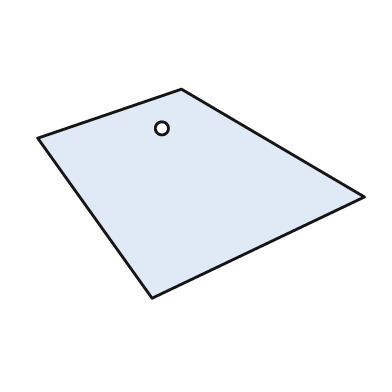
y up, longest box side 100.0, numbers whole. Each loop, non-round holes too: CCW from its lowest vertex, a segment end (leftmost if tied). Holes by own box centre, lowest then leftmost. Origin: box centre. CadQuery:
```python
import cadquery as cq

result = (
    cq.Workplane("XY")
    .moveTo(-15.0, -32.0)
    .lineTo(50.0, -1.0)
    .lineTo(-6.0, 32.0)
    .lineTo(-50.0, 17.0)
    .close()
    .moveTo(-12.0, 20.0)
    .circle(2.0)
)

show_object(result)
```